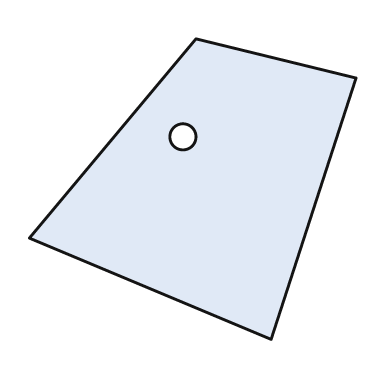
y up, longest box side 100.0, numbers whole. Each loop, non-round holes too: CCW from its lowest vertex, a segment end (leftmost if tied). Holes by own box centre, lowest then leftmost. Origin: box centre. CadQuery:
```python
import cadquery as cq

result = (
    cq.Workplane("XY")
    .moveTo(24.0, -46.0)
    .lineTo(50.0, 34.0)
    .lineTo(1.0, 46.0)
    .lineTo(-50.0, -15.0)
    .close()
    .moveTo(-3.0, 16.0)
    .circle(4.0)
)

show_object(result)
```